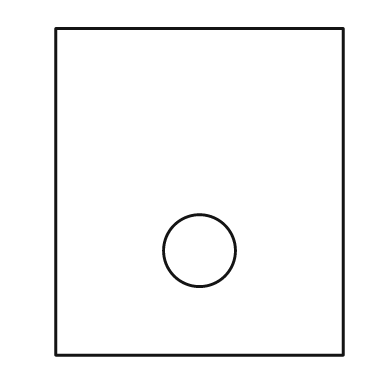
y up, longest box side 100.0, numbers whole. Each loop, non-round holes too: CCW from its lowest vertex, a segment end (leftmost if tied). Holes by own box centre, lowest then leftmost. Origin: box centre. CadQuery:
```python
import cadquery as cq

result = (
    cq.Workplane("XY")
    .moveTo(-44.0, -50.0)
    .lineTo(44.0, -50.0)
    .lineTo(44.0, 50.0)
    .lineTo(-44.0, 50.0)
    .close()
    .moveTo(0.0, -18.0)
    .circle(11.0)
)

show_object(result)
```